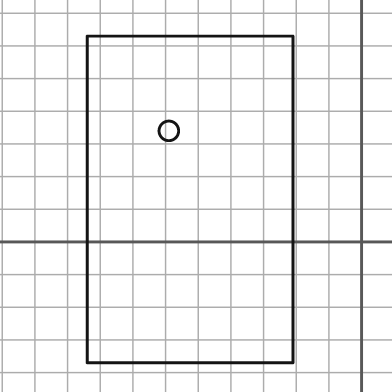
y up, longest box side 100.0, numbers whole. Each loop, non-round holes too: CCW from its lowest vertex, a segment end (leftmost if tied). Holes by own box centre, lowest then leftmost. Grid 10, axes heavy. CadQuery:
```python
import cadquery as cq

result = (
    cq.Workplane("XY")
    .moveTo(-84.0, -37.0)
    .lineTo(-21.0, -37.0)
    .lineTo(-21.0, 63.0)
    .lineTo(-84.0, 63.0)
    .close()
    .moveTo(-59.0, 34.0)
    .circle(3.0)
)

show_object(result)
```